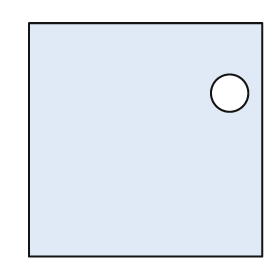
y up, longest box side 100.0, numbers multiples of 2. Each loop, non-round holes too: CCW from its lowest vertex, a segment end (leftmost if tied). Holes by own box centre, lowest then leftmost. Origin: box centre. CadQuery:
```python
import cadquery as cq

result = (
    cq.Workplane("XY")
    .moveTo(-50.0, -50.0)
    .lineTo(50.0, -50.0)
    .lineTo(50.0, 50.0)
    .lineTo(-50.0, 50.0)
    .close()
    .moveTo(36.0, 20.0)
    .circle(8.0)
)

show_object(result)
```